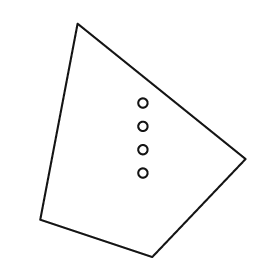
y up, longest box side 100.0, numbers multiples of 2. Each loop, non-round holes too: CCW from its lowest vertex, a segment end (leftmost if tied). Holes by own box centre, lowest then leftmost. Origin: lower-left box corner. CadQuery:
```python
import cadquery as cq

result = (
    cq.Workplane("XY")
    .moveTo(48.0, 0.0)
    .lineTo(88.0, 42.0)
    .lineTo(16.0, 100.0)
    .lineTo(0.0, 16.0)
    .close()
    .moveTo(44.0, 36.0)
    .circle(2.0)
    .moveTo(44.0, 46.0)
    .circle(2.0)
    .moveTo(44.0, 56.0)
    .circle(2.0)
    .moveTo(44.0, 66.0)
    .circle(2.0)
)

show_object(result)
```